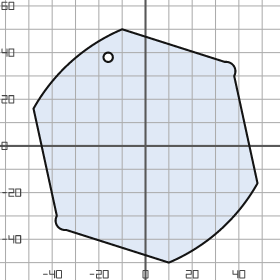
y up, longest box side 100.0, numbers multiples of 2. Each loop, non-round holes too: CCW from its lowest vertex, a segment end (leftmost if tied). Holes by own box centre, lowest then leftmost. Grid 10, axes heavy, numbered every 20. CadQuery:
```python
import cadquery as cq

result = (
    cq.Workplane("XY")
    .moveTo(10.0, -50.0)
    .threePointArc((32.0, -36.0), (48.0, -16.0))
    .lineTo(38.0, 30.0)
    .threePointArc((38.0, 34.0), (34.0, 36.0))
    .lineTo(-10.0, 50.0)
    .threePointArc((-32.0, 36.0), (-48.0, 16.0))
    .lineTo(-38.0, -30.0)
    .threePointArc((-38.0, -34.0), (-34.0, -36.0))
    .close()
    .moveTo(-16.0, 38.0)
    .circle(2.0)
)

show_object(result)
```